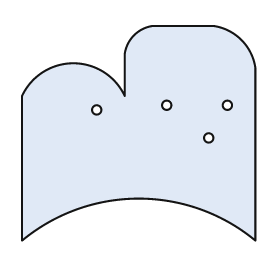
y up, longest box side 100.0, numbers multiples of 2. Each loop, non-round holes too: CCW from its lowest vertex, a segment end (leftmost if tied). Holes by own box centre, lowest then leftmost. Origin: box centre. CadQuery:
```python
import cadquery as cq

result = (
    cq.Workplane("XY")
    .moveTo(-50.0, -46.0)
    .threePointArc((0.0, -28.0), (50.0, -46.0))
    .lineTo(50.0, 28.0)
    .threePointArc((44.0, 40.0), (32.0, 46.0))
    .lineTo(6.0, 46.0)
    .threePointArc((-2.0, 42.0), (-6.0, 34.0))
    .lineTo(-6.0, 16.0)
    .threePointArc((-28.0, 30.0), (-50.0, 16.0))
    .close()
    .moveTo(30.0, -2.0)
    .circle(2.0)
    .moveTo(-18.0, 10.0)
    .circle(2.0)
    .moveTo(12.0, 12.0)
    .circle(2.0)
    .moveTo(38.0, 12.0)
    .circle(2.0)
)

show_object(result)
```